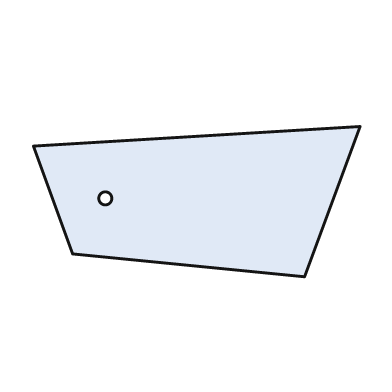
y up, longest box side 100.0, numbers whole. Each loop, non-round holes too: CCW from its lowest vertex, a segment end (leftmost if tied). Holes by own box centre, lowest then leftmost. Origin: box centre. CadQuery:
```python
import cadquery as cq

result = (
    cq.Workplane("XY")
    .moveTo(33.0, -23.0)
    .lineTo(50.0, 23.0)
    .lineTo(-50.0, 17.0)
    .lineTo(-38.0, -16.0)
    .close()
    .moveTo(-28.0, 1.0)
    .circle(2.0)
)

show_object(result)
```